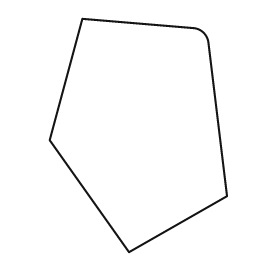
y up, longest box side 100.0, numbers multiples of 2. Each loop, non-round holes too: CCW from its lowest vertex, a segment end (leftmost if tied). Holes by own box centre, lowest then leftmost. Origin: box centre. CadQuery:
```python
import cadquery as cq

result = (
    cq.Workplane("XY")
    .moveTo(-4.0, -50.0)
    .lineTo(38.0, -26.0)
    .lineTo(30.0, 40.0)
    .threePointArc((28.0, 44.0), (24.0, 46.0))
    .lineTo(-24.0, 50.0)
    .lineTo(-38.0, -2.0)
    .close()
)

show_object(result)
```